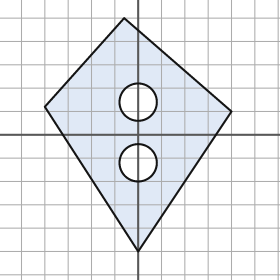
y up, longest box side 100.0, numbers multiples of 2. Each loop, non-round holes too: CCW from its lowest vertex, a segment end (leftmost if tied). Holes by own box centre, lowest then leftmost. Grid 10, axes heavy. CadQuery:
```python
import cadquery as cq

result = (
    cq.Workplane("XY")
    .moveTo(0.0, -50.0)
    .lineTo(40.0, 10.0)
    .lineTo(-6.0, 50.0)
    .lineTo(-40.0, 12.0)
    .close()
    .moveTo(0.0, -12.0)
    .circle(8.0)
    .moveTo(0.0, 14.0)
    .circle(8.0)
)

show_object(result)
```